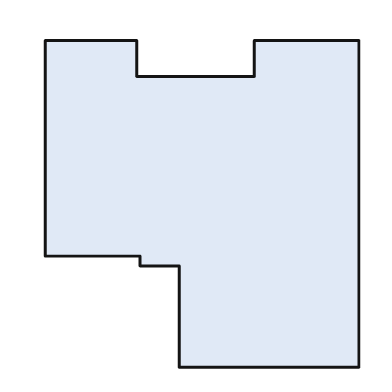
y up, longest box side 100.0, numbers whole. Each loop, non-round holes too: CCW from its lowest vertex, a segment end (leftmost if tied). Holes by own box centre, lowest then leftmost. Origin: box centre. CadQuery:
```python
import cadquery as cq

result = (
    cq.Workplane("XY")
    .moveTo(-7.0, -50.0)
    .lineTo(48.0, -50.0)
    .lineTo(48.0, 50.0)
    .lineTo(16.0, 50.0)
    .lineTo(16.0, 39.0)
    .lineTo(-20.0, 39.0)
    .lineTo(-20.0, 50.0)
    .lineTo(-48.0, 50.0)
    .lineTo(-48.0, -16.0)
    .lineTo(-19.0, -16.0)
    .lineTo(-19.0, -19.0)
    .lineTo(-7.0, -19.0)
    .close()
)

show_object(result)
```